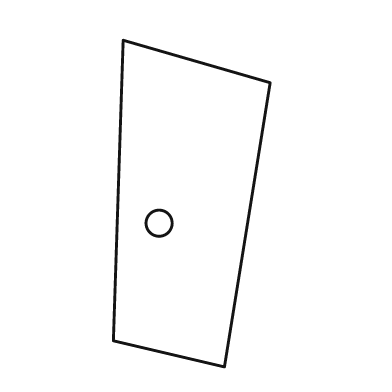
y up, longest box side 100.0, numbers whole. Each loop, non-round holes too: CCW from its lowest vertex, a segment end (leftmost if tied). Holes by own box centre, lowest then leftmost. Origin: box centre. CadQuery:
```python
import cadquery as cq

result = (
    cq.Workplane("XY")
    .moveTo(10.0, -50.0)
    .lineTo(24.0, 37.0)
    .lineTo(-21.0, 50.0)
    .lineTo(-24.0, -42.0)
    .close()
    .moveTo(-10.0, -6.0)
    .circle(4.0)
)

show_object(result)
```